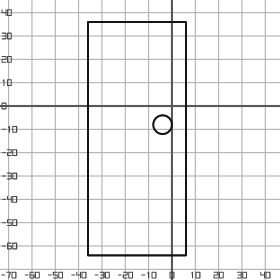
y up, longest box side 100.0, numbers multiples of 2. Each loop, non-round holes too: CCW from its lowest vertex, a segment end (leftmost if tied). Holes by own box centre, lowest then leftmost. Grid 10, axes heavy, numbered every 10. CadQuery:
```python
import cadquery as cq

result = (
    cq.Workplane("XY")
    .moveTo(-36.0, -64.0)
    .lineTo(6.0, -64.0)
    .lineTo(6.0, 36.0)
    .lineTo(-36.0, 36.0)
    .close()
    .moveTo(-4.0, -8.0)
    .circle(4.0)
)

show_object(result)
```